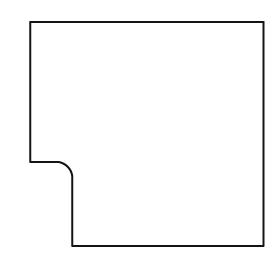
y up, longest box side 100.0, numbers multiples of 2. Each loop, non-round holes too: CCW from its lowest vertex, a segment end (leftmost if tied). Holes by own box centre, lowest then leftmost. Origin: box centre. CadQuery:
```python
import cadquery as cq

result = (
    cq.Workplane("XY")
    .moveTo(-32.0, -48.0)
    .lineTo(50.0, -48.0)
    .lineTo(50.0, 48.0)
    .lineTo(-50.0, 48.0)
    .lineTo(-50.0, -12.0)
    .lineTo(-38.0, -12.0)
    .threePointArc((-34.0, -14.0), (-32.0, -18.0))
    .close()
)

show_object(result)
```